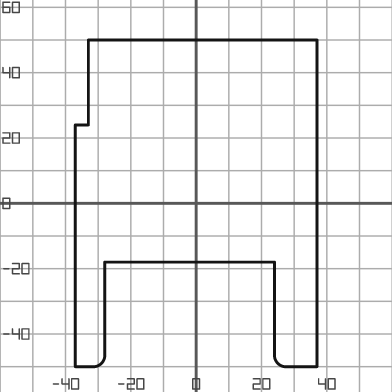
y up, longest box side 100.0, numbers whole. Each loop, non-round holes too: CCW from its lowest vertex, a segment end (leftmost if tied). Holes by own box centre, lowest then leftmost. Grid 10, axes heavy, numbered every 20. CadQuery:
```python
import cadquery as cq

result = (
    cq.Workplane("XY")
    .moveTo(-37.0, -50.0)
    .lineTo(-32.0, -50.0)
    .threePointArc((-29.0, -49.0), (-28.0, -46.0))
    .lineTo(-28.0, -18.0)
    .lineTo(24.0, -18.0)
    .lineTo(24.0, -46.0)
    .threePointArc((25.0, -49.0), (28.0, -50.0))
    .lineTo(37.0, -50.0)
    .lineTo(37.0, 50.0)
    .lineTo(-33.0, 50.0)
    .lineTo(-33.0, 24.0)
    .lineTo(-37.0, 24.0)
    .close()
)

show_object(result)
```